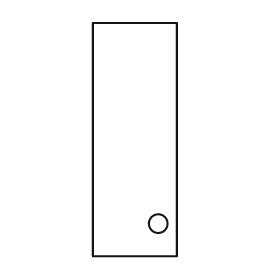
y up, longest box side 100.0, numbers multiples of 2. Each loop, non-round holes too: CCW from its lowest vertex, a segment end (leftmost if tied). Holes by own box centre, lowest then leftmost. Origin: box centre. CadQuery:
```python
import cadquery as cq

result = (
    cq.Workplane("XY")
    .moveTo(-18.0, -50.0)
    .lineTo(18.0, -50.0)
    .lineTo(18.0, 50.0)
    .lineTo(-18.0, 50.0)
    .close()
    .moveTo(10.0, -36.0)
    .circle(4.0)
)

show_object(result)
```